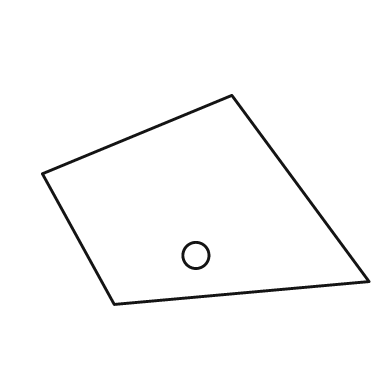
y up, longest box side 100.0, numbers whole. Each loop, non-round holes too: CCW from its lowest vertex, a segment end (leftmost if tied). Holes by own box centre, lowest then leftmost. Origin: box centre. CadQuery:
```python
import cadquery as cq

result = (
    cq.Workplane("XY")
    .moveTo(-28.0, -32.0)
    .lineTo(50.0, -25.0)
    .lineTo(8.0, 32.0)
    .lineTo(-50.0, 8.0)
    .close()
    .moveTo(-3.0, -17.0)
    .circle(4.0)
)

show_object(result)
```